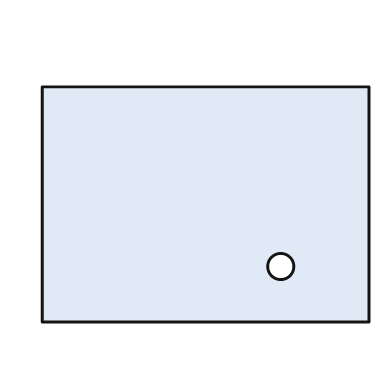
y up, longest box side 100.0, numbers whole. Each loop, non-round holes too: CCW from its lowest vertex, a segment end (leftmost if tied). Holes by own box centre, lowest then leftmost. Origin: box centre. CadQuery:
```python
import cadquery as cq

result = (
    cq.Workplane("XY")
    .moveTo(-50.0, -36.0)
    .lineTo(50.0, -36.0)
    .lineTo(50.0, 36.0)
    .lineTo(-50.0, 36.0)
    .close()
    .moveTo(23.0, -19.0)
    .circle(4.0)
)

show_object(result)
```